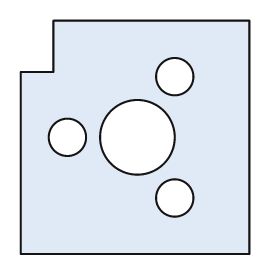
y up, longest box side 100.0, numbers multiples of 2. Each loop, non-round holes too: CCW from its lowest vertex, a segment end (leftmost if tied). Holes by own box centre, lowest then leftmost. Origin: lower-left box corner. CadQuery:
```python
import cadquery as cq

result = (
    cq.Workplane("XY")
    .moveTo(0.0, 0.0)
    .lineTo(98.0, 0.0)
    .lineTo(98.0, 100.0)
    .lineTo(14.0, 100.0)
    .lineTo(14.0, 78.0)
    .lineTo(0.0, 78.0)
    .close()
    .moveTo(66.0, 24.0)
    .circle(8.0)
    .moveTo(20.0, 50.0)
    .circle(8.0)
    .moveTo(50.0, 50.0)
    .circle(16.0)
    .moveTo(66.0, 76.0)
    .circle(8.0)
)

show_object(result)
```